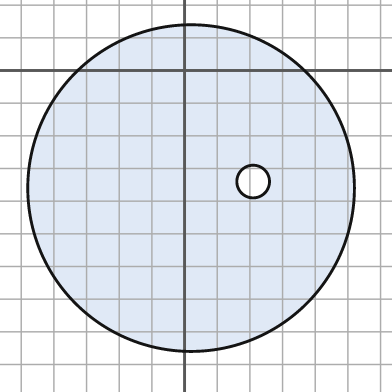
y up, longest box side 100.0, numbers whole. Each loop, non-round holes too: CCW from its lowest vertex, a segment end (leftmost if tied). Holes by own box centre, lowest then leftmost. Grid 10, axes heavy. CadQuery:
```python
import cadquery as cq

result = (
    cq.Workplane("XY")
    .moveTo(2.0, -36.0)
    .circle(50.0)
    .moveTo(21.0, -34.0)
    .circle(5.0)
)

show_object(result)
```